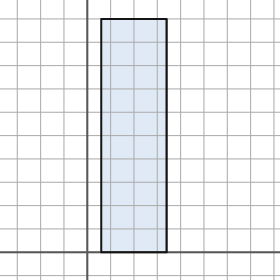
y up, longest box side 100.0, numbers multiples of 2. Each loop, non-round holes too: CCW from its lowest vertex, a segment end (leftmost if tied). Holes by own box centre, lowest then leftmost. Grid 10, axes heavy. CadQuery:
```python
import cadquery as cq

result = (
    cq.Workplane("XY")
    .moveTo(6.0, 0.0)
    .lineTo(34.0, 0.0)
    .lineTo(34.0, 100.0)
    .lineTo(6.0, 100.0)
    .close()
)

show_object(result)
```